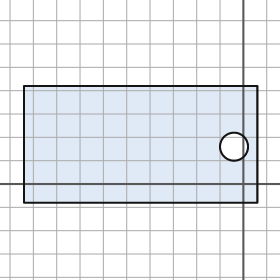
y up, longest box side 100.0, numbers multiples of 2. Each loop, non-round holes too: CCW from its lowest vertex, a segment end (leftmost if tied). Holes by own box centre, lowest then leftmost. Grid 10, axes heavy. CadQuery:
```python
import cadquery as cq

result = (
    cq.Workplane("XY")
    .moveTo(-94.0, -8.0)
    .lineTo(6.0, -8.0)
    .lineTo(6.0, 42.0)
    .lineTo(-94.0, 42.0)
    .close()
    .moveTo(-4.0, 16.0)
    .circle(6.0)
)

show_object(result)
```